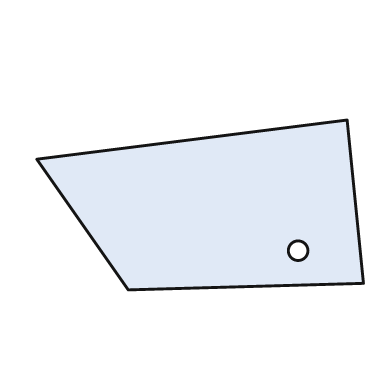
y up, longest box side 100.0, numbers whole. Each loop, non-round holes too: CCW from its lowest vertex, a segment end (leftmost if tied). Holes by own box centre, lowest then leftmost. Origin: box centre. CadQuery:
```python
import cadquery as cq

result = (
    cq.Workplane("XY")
    .moveTo(-22.0, -26.0)
    .lineTo(50.0, -24.0)
    .lineTo(45.0, 26.0)
    .lineTo(-50.0, 14.0)
    .close()
    .moveTo(30.0, -14.0)
    .circle(3.0)
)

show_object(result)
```